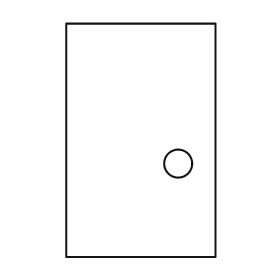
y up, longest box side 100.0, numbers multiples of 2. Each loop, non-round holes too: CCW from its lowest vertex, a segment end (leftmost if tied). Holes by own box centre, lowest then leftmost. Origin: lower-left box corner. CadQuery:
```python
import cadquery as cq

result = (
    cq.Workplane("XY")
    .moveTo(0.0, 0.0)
    .lineTo(64.0, 0.0)
    .lineTo(64.0, 100.0)
    .lineTo(0.0, 100.0)
    .close()
    .moveTo(48.0, 40.0)
    .circle(6.0)
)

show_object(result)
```